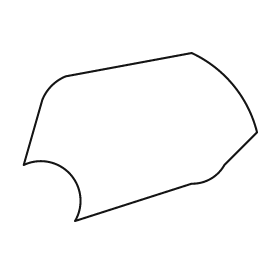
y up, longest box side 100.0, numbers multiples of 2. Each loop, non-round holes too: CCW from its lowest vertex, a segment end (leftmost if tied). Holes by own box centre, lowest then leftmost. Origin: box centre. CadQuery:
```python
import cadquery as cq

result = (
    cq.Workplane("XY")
    .moveTo(-28.0, -36.0)
    .lineTo(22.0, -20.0)
    .threePointArc((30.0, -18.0), (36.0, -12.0))
    .lineTo(50.0, 2.0)
    .threePointArc((40.0, 22.0), (22.0, 36.0))
    .lineTo(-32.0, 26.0)
    .threePointArc((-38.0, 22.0), (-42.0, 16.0))
    .lineTo(-50.0, -12.0)
    .threePointArc((-30.0, -16.0), (-28.0, -36.0))
    .close()
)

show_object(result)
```